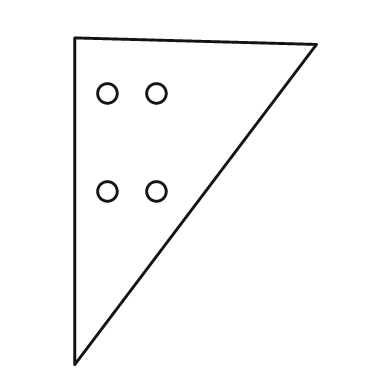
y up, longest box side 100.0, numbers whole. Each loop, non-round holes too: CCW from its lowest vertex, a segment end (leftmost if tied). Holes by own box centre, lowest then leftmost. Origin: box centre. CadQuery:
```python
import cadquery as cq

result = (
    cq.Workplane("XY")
    .moveTo(-37.0, -50.0)
    .lineTo(37.0, 48.0)
    .lineTo(-37.0, 50.0)
    .close()
    .moveTo(-27.0, 3.0)
    .circle(3.0)
    .moveTo(-12.0, 3.0)
    .circle(3.0)
    .moveTo(-27.0, 33.0)
    .circle(3.0)
    .moveTo(-12.0, 33.0)
    .circle(3.0)
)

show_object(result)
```